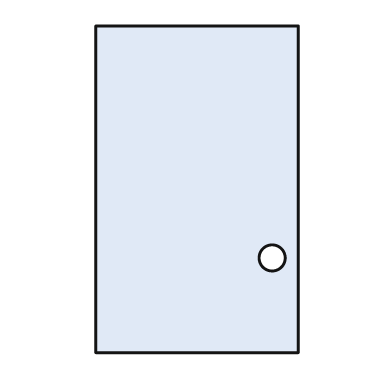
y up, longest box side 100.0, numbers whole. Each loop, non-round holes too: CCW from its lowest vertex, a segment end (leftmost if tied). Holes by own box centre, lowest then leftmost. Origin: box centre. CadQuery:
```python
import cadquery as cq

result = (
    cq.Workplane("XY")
    .moveTo(-31.0, -50.0)
    .lineTo(31.0, -50.0)
    .lineTo(31.0, 50.0)
    .lineTo(-31.0, 50.0)
    .close()
    .moveTo(23.0, -21.0)
    .circle(4.0)
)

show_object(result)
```